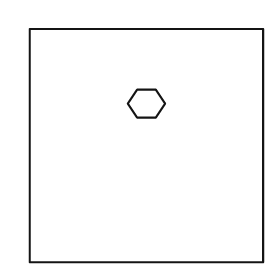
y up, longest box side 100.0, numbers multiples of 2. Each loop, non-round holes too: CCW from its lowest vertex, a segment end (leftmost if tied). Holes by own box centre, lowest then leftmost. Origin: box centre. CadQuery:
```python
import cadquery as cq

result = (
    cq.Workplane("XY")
    .moveTo(-50.0, -50.0)
    .lineTo(50.0, -50.0)
    .lineTo(50.0, 50.0)
    .lineTo(-50.0, 50.0)
    .close()
    .moveTo(-4.0, 12.0)
    .lineTo(4.0, 12.0)
    .lineTo(8.0, 18.0)
    .lineTo(4.0, 24.0)
    .lineTo(-4.0, 24.0)
    .lineTo(-8.0, 18.0)
    .close()
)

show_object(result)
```